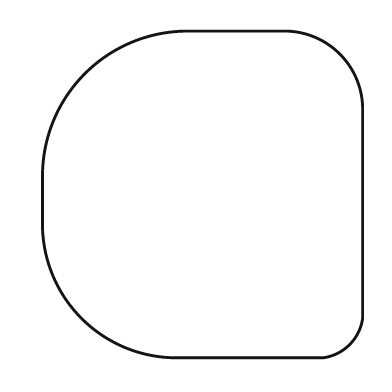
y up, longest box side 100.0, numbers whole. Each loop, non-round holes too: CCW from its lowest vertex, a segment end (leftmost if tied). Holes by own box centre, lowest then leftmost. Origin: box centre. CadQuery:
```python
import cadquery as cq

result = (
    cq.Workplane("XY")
    .moveTo(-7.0, -50.0)
    .lineTo(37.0, -50.0)
    .threePointArc((45.0, -46.0), (49.0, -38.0))
    .lineTo(49.0, 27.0)
    .threePointArc((42.0, 43.0), (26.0, 50.0))
    .lineTo(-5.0, 50.0)
    .threePointArc((-36.0, 37.0), (-49.0, 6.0))
    .lineTo(-49.0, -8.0)
    .threePointArc((-37.0, -38.0), (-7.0, -50.0))
    .close()
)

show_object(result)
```